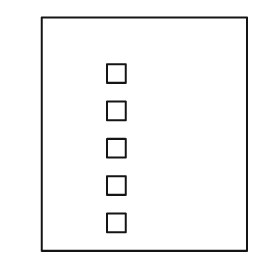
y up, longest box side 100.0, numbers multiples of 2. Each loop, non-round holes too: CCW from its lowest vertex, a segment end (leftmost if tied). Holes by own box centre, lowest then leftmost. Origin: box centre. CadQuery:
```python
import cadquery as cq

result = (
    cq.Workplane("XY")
    .moveTo(-44.0, -50.0)
    .lineTo(44.0, -50.0)
    .lineTo(44.0, 50.0)
    .lineTo(-44.0, 50.0)
    .close()
    .moveTo(-16.0, -42.0)
    .lineTo(-8.0, -42.0)
    .lineTo(-8.0, -34.0)
    .lineTo(-16.0, -34.0)
    .close()
    .moveTo(-16.0, -26.0)
    .lineTo(-8.0, -26.0)
    .lineTo(-8.0, -18.0)
    .lineTo(-16.0, -18.0)
    .close()
    .moveTo(-16.0, -10.0)
    .lineTo(-8.0, -10.0)
    .lineTo(-8.0, -2.0)
    .lineTo(-16.0, -2.0)
    .close()
    .moveTo(-16.0, 6.0)
    .lineTo(-8.0, 6.0)
    .lineTo(-8.0, 14.0)
    .lineTo(-16.0, 14.0)
    .close()
    .moveTo(-16.0, 22.0)
    .lineTo(-8.0, 22.0)
    .lineTo(-8.0, 30.0)
    .lineTo(-16.0, 30.0)
    .close()
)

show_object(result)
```